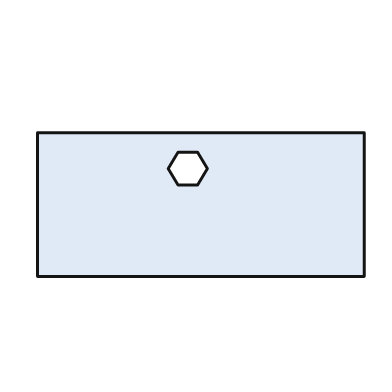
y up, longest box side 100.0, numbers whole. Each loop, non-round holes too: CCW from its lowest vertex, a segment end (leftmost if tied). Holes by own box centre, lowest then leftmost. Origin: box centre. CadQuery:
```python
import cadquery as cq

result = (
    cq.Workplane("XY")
    .moveTo(-50.0, -22.0)
    .lineTo(50.0, -22.0)
    .lineTo(50.0, 22.0)
    .lineTo(-50.0, 22.0)
    .close()
    .moveTo(-7.0, 6.0)
    .lineTo(-1.0, 6.0)
    .lineTo(2.0, 11.0)
    .lineTo(-1.0, 16.0)
    .lineTo(-7.0, 16.0)
    .lineTo(-10.0, 11.0)
    .close()
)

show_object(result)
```